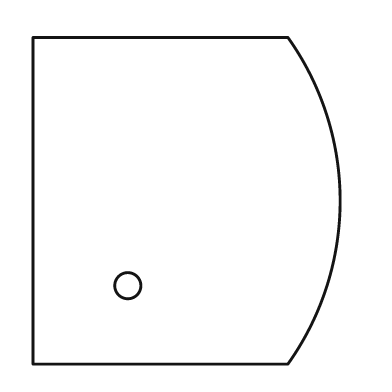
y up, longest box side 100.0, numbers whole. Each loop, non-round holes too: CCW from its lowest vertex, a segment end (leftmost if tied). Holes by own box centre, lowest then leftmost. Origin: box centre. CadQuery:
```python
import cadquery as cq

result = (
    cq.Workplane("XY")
    .moveTo(-47.0, -50.0)
    .lineTo(31.0, -50.0)
    .threePointArc((47.0, 0.0), (31.0, 50.0))
    .lineTo(-47.0, 50.0)
    .close()
    .moveTo(-18.0, -26.0)
    .circle(4.0)
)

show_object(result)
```